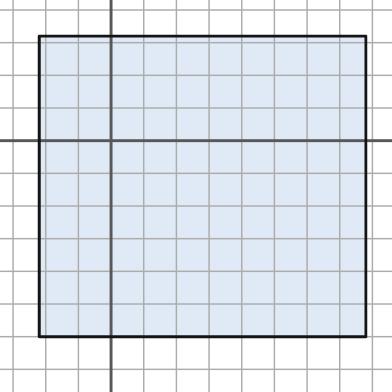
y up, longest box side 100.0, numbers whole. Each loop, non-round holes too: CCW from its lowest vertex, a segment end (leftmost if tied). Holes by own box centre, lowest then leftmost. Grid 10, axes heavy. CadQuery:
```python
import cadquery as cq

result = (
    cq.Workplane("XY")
    .moveTo(-22.0, -60.0)
    .lineTo(78.0, -60.0)
    .lineTo(78.0, 32.0)
    .lineTo(-22.0, 32.0)
    .close()
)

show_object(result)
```